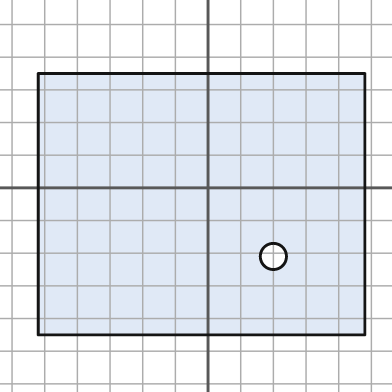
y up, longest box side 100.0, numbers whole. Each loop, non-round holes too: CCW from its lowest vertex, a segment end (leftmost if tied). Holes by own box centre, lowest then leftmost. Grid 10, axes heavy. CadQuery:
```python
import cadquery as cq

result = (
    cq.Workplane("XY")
    .moveTo(-52.0, -45.0)
    .lineTo(48.0, -45.0)
    .lineTo(48.0, 35.0)
    .lineTo(-52.0, 35.0)
    .close()
    .moveTo(20.0, -21.0)
    .circle(4.0)
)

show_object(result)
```